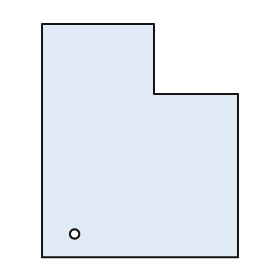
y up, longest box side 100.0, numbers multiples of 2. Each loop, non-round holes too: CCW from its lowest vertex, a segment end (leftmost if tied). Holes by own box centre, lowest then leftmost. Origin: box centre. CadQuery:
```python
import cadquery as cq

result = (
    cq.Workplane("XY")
    .moveTo(-42.0, -50.0)
    .lineTo(42.0, -50.0)
    .lineTo(42.0, 20.0)
    .lineTo(6.0, 20.0)
    .lineTo(6.0, 50.0)
    .lineTo(-42.0, 50.0)
    .close()
    .moveTo(-28.0, -40.0)
    .circle(2.0)
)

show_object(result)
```